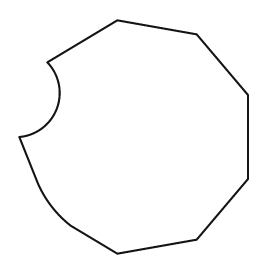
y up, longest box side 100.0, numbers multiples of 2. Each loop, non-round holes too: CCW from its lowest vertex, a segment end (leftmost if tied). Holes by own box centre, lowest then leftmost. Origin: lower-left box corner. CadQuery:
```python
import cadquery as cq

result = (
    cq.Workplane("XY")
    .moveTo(42.0, 0.0)
    .lineTo(76.0, 6.0)
    .lineTo(98.0, 32.0)
    .lineTo(98.0, 68.0)
    .lineTo(76.0, 94.0)
    .lineTo(42.0, 100.0)
    .lineTo(12.0, 82.0)
    .threePointArc((16.0, 62.0), (0.0, 50.0))
    .lineTo(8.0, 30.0)
    .threePointArc((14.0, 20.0), (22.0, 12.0))
    .close()
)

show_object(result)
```